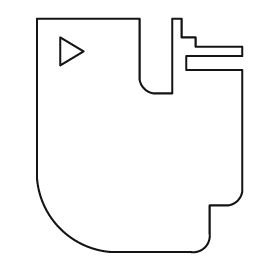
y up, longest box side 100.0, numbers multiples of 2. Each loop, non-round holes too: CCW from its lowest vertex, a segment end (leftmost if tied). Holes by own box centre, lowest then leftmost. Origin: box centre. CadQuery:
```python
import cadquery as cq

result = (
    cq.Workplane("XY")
    .moveTo(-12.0, -50.0)
    .lineTo(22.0, -50.0)
    .threePointArc((28.0, -48.0), (30.0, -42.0))
    .lineTo(30.0, -30.0)
    .lineTo(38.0, -30.0)
    .threePointArc((42.0, -28.0), (44.0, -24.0))
    .lineTo(44.0, 28.0)
    .lineTo(20.0, 28.0)
    .lineTo(20.0, 34.0)
    .lineTo(44.0, 34.0)
    .lineTo(44.0, 38.0)
    .lineTo(24.0, 38.0)
    .lineTo(24.0, 42.0)
    .lineTo(18.0, 42.0)
    .lineTo(18.0, 50.0)
    .lineTo(14.0, 50.0)
    .lineTo(14.0, 18.0)
    .lineTo(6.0, 18.0)
    .threePointArc((2.0, 20.0), (0.0, 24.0))
    .lineTo(0.0, 50.0)
    .lineTo(-44.0, 50.0)
    .lineTo(-44.0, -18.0)
    .threePointArc((-34.0, -40.0), (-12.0, -50.0))
    .close()
    .moveTo(-34.0, 30.0)
    .lineTo(-24.0, 36.0)
    .lineTo(-34.0, 42.0)
    .close()
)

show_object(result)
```